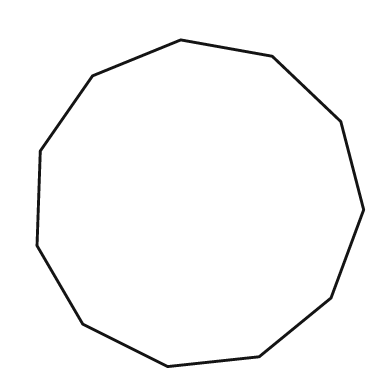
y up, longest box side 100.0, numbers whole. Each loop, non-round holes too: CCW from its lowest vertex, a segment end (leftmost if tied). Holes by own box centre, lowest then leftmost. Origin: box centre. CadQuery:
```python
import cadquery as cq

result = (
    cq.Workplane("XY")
    .moveTo(-10.0, -50.0)
    .lineTo(18.0, -47.0)
    .lineTo(40.0, -29.0)
    .lineTo(50.0, -2.0)
    .lineTo(43.0, 25.0)
    .lineTo(22.0, 45.0)
    .lineTo(-6.0, 50.0)
    .lineTo(-33.0, 39.0)
    .lineTo(-49.0, 16.0)
    .lineTo(-50.0, -13.0)
    .lineTo(-36.0, -37.0)
    .close()
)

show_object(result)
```